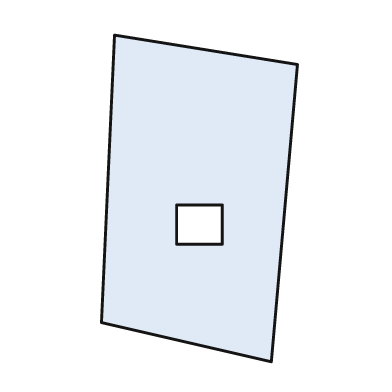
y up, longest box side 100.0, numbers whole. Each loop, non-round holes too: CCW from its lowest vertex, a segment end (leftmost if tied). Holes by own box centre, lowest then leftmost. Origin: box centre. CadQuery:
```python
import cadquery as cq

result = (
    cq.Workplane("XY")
    .moveTo(22.0, -50.0)
    .lineTo(30.0, 41.0)
    .lineTo(-26.0, 50.0)
    .lineTo(-30.0, -38.0)
    .close()
    .moveTo(-7.0, -14.0)
    .lineTo(7.0, -14.0)
    .lineTo(7.0, -2.0)
    .lineTo(-7.0, -2.0)
    .close()
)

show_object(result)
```